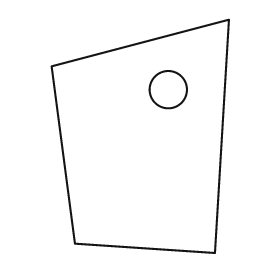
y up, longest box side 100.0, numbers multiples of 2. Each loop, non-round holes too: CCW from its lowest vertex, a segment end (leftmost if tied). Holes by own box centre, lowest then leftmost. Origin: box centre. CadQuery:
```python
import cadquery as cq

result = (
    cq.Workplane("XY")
    .moveTo(32.0, -50.0)
    .lineTo(38.0, 50.0)
    .lineTo(-38.0, 30.0)
    .lineTo(-28.0, -46.0)
    .close()
    .moveTo(12.0, 20.0)
    .circle(8.0)
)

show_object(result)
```